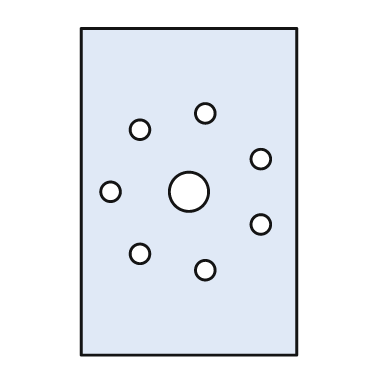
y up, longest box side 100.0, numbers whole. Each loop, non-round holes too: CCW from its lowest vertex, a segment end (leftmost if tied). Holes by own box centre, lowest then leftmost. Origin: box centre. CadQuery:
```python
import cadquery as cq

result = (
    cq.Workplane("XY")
    .moveTo(-33.0, -50.0)
    .lineTo(33.0, -50.0)
    .lineTo(33.0, 50.0)
    .lineTo(-33.0, 50.0)
    .close()
    .moveTo(5.0, -24.0)
    .circle(3.0)
    .moveTo(-15.0, -19.0)
    .circle(3.0)
    .moveTo(22.0, -10.0)
    .circle(3.0)
    .moveTo(-24.0, 0.0)
    .circle(3.0)
    .moveTo(0.0, 0.0)
    .circle(6.0)
    .moveTo(22.0, 10.0)
    .circle(3.0)
    .moveTo(-15.0, 19.0)
    .circle(3.0)
    .moveTo(5.0, 24.0)
    .circle(3.0)
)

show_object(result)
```